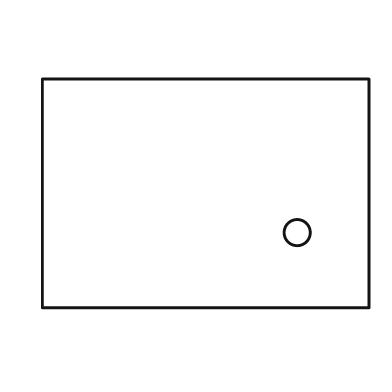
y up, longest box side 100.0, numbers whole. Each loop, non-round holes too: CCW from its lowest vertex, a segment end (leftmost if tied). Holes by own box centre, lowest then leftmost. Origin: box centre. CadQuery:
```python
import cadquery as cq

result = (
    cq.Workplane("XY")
    .moveTo(-50.0, -35.0)
    .lineTo(50.0, -35.0)
    .lineTo(50.0, 35.0)
    .lineTo(-50.0, 35.0)
    .close()
    .moveTo(28.0, -12.0)
    .circle(4.0)
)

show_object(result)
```